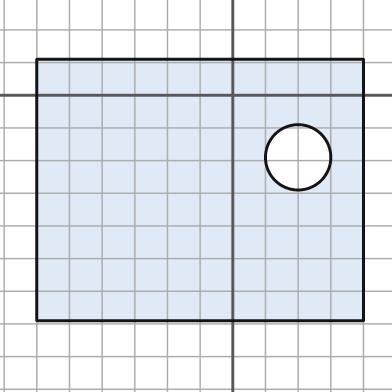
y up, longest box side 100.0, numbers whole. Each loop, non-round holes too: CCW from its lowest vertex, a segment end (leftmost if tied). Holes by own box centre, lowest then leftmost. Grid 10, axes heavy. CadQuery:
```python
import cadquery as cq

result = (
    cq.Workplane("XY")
    .moveTo(-60.0, -69.0)
    .lineTo(40.0, -69.0)
    .lineTo(40.0, 11.0)
    .lineTo(-60.0, 11.0)
    .close()
    .moveTo(20.0, -19.0)
    .circle(10.0)
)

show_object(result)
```